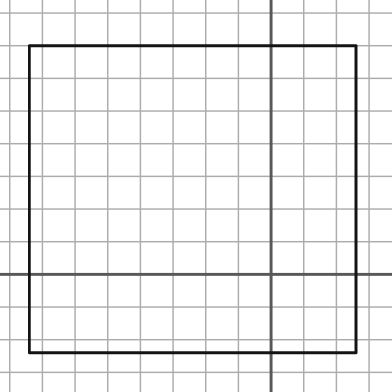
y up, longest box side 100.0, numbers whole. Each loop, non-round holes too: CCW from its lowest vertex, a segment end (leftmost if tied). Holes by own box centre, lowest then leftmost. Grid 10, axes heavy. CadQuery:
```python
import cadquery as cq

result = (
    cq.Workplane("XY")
    .moveTo(-74.0, -24.0)
    .lineTo(26.0, -24.0)
    .lineTo(26.0, 70.0)
    .lineTo(-74.0, 70.0)
    .close()
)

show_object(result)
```